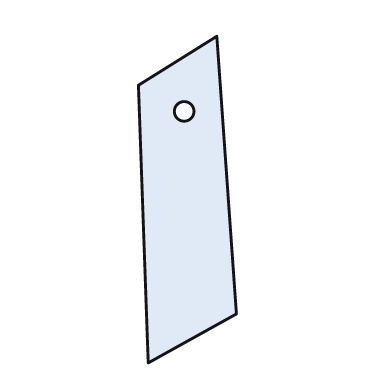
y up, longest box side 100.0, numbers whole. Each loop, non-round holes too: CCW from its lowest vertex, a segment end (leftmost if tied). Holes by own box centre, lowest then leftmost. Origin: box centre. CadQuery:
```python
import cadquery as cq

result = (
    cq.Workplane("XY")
    .moveTo(-12.0, -50.0)
    .lineTo(15.0, -35.0)
    .lineTo(9.0, 50.0)
    .lineTo(-15.0, 35.0)
    .close()
    .moveTo(-1.0, 27.0)
    .circle(3.0)
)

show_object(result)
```